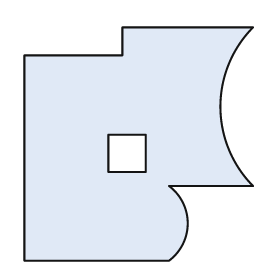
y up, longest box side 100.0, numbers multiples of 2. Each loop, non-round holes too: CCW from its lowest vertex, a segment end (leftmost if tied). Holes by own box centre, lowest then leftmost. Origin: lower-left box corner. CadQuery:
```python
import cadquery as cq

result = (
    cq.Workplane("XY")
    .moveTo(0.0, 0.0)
    .lineTo(62.0, 0.0)
    .threePointArc((70.0, 16.0), (62.0, 32.0))
    .lineTo(98.0, 32.0)
    .threePointArc((84.0, 66.0), (98.0, 100.0))
    .lineTo(42.0, 100.0)
    .lineTo(42.0, 88.0)
    .lineTo(0.0, 88.0)
    .close()
    .moveTo(36.0, 38.0)
    .lineTo(52.0, 38.0)
    .lineTo(52.0, 54.0)
    .lineTo(36.0, 54.0)
    .close()
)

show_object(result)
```